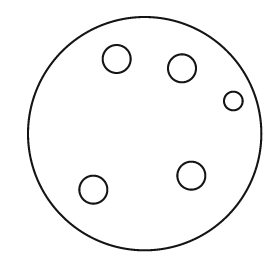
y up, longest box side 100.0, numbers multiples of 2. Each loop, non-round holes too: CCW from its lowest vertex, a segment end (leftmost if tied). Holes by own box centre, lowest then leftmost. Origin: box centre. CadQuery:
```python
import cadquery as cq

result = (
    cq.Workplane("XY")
    .moveTo(0.0, 0.0)
    .circle(50.0)
    .moveTo(-22.0, -24.0)
    .circle(6.0)
    .moveTo(20.0, -18.0)
    .circle(6.0)
    .moveTo(38.0, 14.0)
    .circle(4.0)
    .moveTo(16.0, 28.0)
    .circle(6.0)
    .moveTo(-12.0, 32.0)
    .circle(6.0)
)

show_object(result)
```